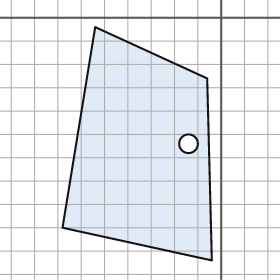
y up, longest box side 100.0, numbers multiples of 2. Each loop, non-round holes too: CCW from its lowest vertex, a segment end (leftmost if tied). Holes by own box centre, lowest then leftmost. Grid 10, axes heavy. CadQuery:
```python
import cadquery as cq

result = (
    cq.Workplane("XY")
    .moveTo(-4.0, -104.0)
    .lineTo(-6.0, -26.0)
    .lineTo(-54.0, -4.0)
    .lineTo(-68.0, -90.0)
    .close()
    .moveTo(-14.0, -54.0)
    .circle(4.0)
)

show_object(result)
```